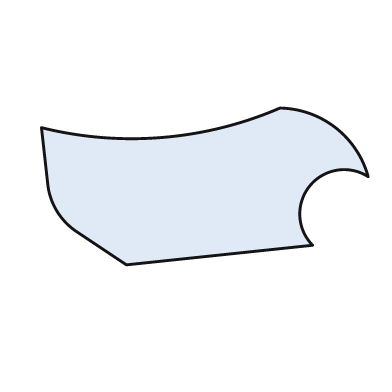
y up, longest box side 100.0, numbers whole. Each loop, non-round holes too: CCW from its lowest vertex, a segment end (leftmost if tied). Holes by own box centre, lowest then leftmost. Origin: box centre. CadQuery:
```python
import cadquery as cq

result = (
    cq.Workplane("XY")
    .moveTo(-24.0, -24.0)
    .lineTo(33.0, -18.0)
    .threePointArc((32.0, 0.0), (50.0, 3.0))
    .threePointArc((40.0, 18.0), (23.0, 24.0))
    .threePointArc((-13.0, 15.0), (-50.0, 18.0))
    .lineTo(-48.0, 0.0)
    .threePointArc((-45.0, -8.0), (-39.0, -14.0))
    .close()
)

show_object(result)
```